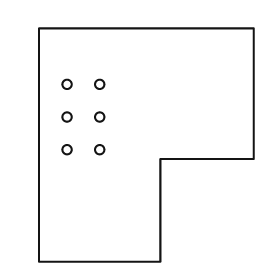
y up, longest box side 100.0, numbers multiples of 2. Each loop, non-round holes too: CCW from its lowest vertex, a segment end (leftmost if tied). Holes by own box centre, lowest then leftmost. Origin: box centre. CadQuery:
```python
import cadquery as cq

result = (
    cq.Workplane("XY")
    .moveTo(-46.0, -50.0)
    .lineTo(6.0, -50.0)
    .lineTo(6.0, -6.0)
    .lineTo(46.0, -6.0)
    .lineTo(46.0, 50.0)
    .lineTo(-46.0, 50.0)
    .close()
    .moveTo(-34.0, -2.0)
    .circle(2.0)
    .moveTo(-20.0, -2.0)
    .circle(2.0)
    .moveTo(-34.0, 12.0)
    .circle(2.0)
    .moveTo(-20.0, 12.0)
    .circle(2.0)
    .moveTo(-34.0, 26.0)
    .circle(2.0)
    .moveTo(-20.0, 26.0)
    .circle(2.0)
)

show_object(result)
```